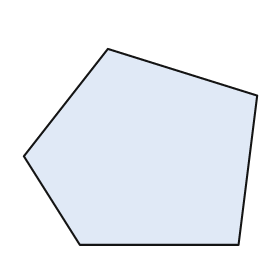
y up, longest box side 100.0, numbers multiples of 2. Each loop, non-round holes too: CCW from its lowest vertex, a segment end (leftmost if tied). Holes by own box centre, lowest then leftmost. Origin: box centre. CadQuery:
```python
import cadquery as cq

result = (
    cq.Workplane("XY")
    .moveTo(-26.0, -42.0)
    .lineTo(42.0, -42.0)
    .lineTo(50.0, 22.0)
    .lineTo(-14.0, 42.0)
    .lineTo(-50.0, -4.0)
    .close()
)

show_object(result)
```